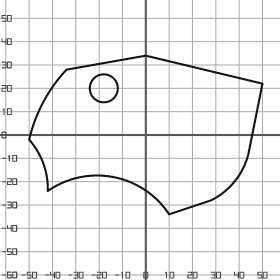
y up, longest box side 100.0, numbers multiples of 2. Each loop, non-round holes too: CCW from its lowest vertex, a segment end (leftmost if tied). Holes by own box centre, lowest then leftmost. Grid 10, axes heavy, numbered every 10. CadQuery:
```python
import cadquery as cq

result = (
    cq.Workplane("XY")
    .moveTo(10.0, -34.0)
    .lineTo(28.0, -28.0)
    .threePointArc((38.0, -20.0), (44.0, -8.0))
    .lineTo(50.0, 22.0)
    .lineTo(0.0, 34.0)
    .lineTo(-34.0, 28.0)
    .threePointArc((-44.0, 14.0), (-50.0, -2.0))
    .threePointArc((-44.0, -12.0), (-42.0, -24.0))
    .threePointArc((-14.0, -18.0), (10.0, -34.0))
    .close()
    .moveTo(-18.0, 20.0)
    .circle(6.0)
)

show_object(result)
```